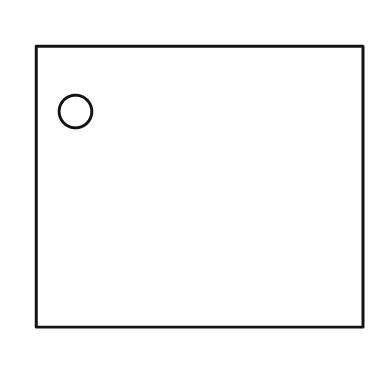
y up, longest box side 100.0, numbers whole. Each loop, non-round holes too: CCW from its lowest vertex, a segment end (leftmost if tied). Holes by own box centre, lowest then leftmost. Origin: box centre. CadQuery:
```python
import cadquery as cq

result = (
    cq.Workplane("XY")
    .moveTo(-50.0, -43.0)
    .lineTo(50.0, -43.0)
    .lineTo(50.0, 43.0)
    .lineTo(-50.0, 43.0)
    .close()
    .moveTo(-38.0, 23.0)
    .circle(5.0)
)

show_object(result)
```